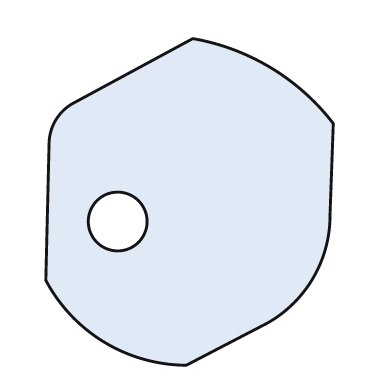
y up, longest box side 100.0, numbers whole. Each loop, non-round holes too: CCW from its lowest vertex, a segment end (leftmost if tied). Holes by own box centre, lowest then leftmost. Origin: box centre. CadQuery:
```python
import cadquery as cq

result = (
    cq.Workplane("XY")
    .moveTo(-1.0, -50.0)
    .lineTo(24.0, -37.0)
    .threePointArc((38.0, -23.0), (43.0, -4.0))
    .lineTo(44.0, 24.0)
    .threePointArc((25.0, 41.0), (1.0, 50.0))
    .lineTo(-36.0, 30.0)
    .threePointArc((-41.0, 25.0), (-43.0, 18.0))
    .lineTo(-44.0, -24.0)
    .threePointArc((-26.0, -43.0), (-1.0, -50.0))
    .close()
    .moveTo(-22.0, -6.0)
    .circle(9.0)
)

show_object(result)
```